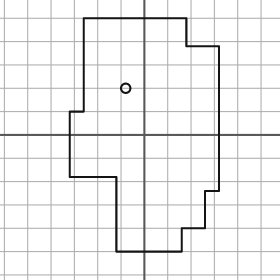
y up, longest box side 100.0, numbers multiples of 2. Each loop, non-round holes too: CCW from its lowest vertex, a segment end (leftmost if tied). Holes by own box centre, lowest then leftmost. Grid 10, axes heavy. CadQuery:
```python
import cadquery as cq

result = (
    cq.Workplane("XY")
    .moveTo(-12.0, -50.0)
    .lineTo(16.0, -50.0)
    .lineTo(16.0, -40.0)
    .lineTo(26.0, -40.0)
    .lineTo(26.0, -24.0)
    .lineTo(32.0, -24.0)
    .lineTo(32.0, 38.0)
    .lineTo(18.0, 38.0)
    .lineTo(18.0, 50.0)
    .lineTo(-26.0, 50.0)
    .lineTo(-26.0, 10.0)
    .lineTo(-32.0, 10.0)
    .lineTo(-32.0, -18.0)
    .lineTo(-12.0, -18.0)
    .close()
    .moveTo(-8.0, 20.0)
    .circle(2.0)
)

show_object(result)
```